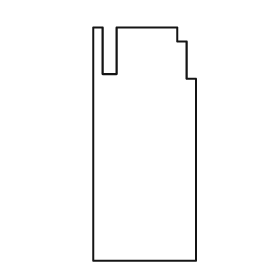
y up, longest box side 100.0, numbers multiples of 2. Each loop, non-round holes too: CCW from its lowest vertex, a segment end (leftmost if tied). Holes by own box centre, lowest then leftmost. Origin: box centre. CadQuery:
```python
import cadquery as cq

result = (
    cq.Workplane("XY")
    .moveTo(-22.0, -50.0)
    .lineTo(22.0, -50.0)
    .lineTo(22.0, 28.0)
    .lineTo(18.0, 28.0)
    .lineTo(18.0, 44.0)
    .lineTo(14.0, 44.0)
    .lineTo(14.0, 50.0)
    .lineTo(-12.0, 50.0)
    .lineTo(-12.0, 30.0)
    .lineTo(-18.0, 30.0)
    .lineTo(-18.0, 50.0)
    .lineTo(-22.0, 50.0)
    .close()
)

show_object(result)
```